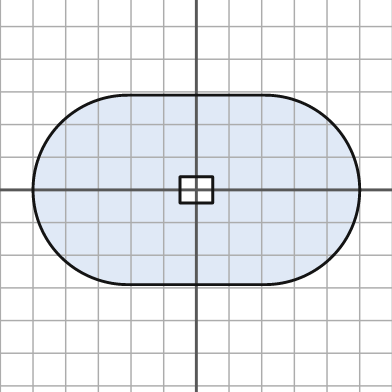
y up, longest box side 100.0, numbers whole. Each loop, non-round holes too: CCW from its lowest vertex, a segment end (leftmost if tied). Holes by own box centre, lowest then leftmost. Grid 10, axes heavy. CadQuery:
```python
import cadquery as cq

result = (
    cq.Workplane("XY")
    .moveTo(-21.0, -29.0)
    .lineTo(21.0, -29.0)
    .threePointArc((50.0, 0.0), (21.0, 29.0))
    .lineTo(-21.0, 29.0)
    .threePointArc((-50.0, 0.0), (-21.0, -29.0))
    .close()
    .moveTo(-5.0, -4.0)
    .lineTo(5.0, -4.0)
    .lineTo(5.0, 4.0)
    .lineTo(-5.0, 4.0)
    .close()
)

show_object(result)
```